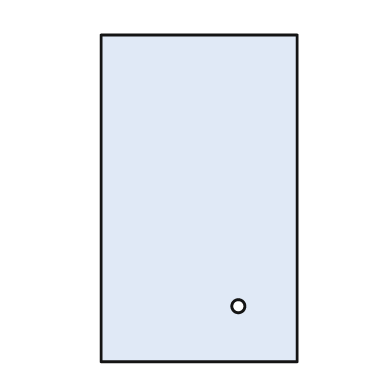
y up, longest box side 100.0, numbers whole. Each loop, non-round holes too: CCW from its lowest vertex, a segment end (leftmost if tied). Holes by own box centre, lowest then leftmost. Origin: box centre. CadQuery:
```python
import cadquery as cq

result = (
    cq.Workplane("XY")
    .moveTo(-30.0, -50.0)
    .lineTo(30.0, -50.0)
    .lineTo(30.0, 50.0)
    .lineTo(-30.0, 50.0)
    .close()
    .moveTo(12.0, -33.0)
    .circle(2.0)
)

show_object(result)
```